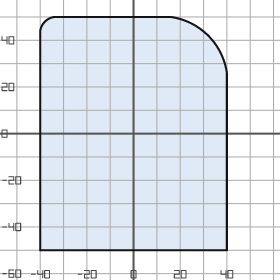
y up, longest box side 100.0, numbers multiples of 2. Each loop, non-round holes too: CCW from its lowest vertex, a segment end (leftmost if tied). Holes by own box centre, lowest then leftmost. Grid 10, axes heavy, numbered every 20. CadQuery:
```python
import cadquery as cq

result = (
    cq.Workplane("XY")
    .moveTo(-40.0, -50.0)
    .lineTo(40.0, -50.0)
    .lineTo(40.0, 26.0)
    .threePointArc((32.0, 42.0), (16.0, 50.0))
    .lineTo(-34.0, 50.0)
    .threePointArc((-38.0, 48.0), (-40.0, 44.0))
    .close()
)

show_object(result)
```